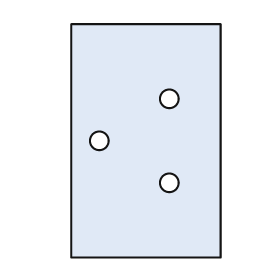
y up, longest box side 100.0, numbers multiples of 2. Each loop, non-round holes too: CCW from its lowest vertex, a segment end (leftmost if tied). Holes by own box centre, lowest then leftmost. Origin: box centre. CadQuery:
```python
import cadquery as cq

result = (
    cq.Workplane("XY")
    .moveTo(-32.0, -50.0)
    .lineTo(32.0, -50.0)
    .lineTo(32.0, 50.0)
    .lineTo(-32.0, 50.0)
    .close()
    .moveTo(10.0, -18.0)
    .circle(4.0)
    .moveTo(-20.0, 0.0)
    .circle(4.0)
    .moveTo(10.0, 18.0)
    .circle(4.0)
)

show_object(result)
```